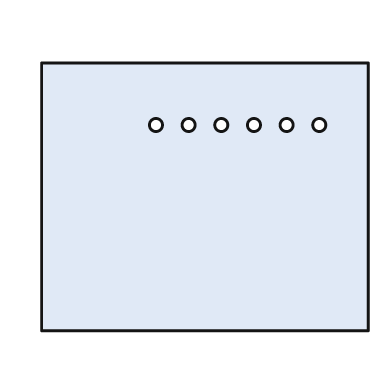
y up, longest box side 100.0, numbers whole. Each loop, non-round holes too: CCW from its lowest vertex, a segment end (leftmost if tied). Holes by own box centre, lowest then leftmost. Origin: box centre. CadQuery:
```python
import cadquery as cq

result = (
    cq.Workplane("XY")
    .moveTo(-50.0, -41.0)
    .lineTo(50.0, -41.0)
    .lineTo(50.0, 41.0)
    .lineTo(-50.0, 41.0)
    .close()
    .moveTo(-15.0, 22.0)
    .circle(2.0)
    .moveTo(-5.0, 22.0)
    .circle(2.0)
    .moveTo(5.0, 22.0)
    .circle(2.0)
    .moveTo(15.0, 22.0)
    .circle(2.0)
    .moveTo(25.0, 22.0)
    .circle(2.0)
    .moveTo(35.0, 22.0)
    .circle(2.0)
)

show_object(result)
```